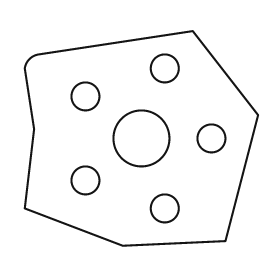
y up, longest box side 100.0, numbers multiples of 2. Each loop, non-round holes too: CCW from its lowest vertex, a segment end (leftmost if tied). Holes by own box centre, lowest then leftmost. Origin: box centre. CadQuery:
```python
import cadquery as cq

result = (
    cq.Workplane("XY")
    .moveTo(-8.0, -46.0)
    .lineTo(36.0, -44.0)
    .lineTo(50.0, 10.0)
    .lineTo(22.0, 46.0)
    .lineTo(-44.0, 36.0)
    .threePointArc((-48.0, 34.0), (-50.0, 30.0))
    .lineTo(-46.0, 4.0)
    .lineTo(-50.0, -30.0)
    .close()
    .moveTo(10.0, -30.0)
    .circle(6.0)
    .moveTo(-24.0, -18.0)
    .circle(6.0)
    .moveTo(0.0, 0.0)
    .circle(12.0)
    .moveTo(30.0, 0.0)
    .circle(6.0)
    .moveTo(-24.0, 18.0)
    .circle(6.0)
    .moveTo(10.0, 30.0)
    .circle(6.0)
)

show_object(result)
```